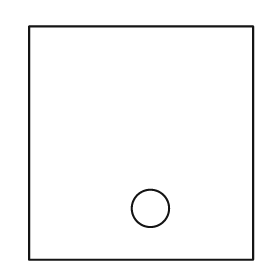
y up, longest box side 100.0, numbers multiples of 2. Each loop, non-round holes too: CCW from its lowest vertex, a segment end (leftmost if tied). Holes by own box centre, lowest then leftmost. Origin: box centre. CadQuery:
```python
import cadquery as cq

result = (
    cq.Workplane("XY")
    .moveTo(-48.0, -50.0)
    .lineTo(48.0, -50.0)
    .lineTo(48.0, 50.0)
    .lineTo(-48.0, 50.0)
    .close()
    .moveTo(4.0, -28.0)
    .circle(8.0)
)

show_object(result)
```